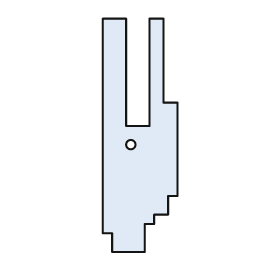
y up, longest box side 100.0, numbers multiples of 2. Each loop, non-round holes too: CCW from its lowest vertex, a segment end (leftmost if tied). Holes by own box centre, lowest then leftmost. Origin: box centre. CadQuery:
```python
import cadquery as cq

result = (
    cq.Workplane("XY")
    .moveTo(-12.0, -50.0)
    .lineTo(2.0, -50.0)
    .lineTo(2.0, -38.0)
    .lineTo(6.0, -38.0)
    .lineTo(6.0, -34.0)
    .lineTo(12.0, -34.0)
    .lineTo(12.0, -26.0)
    .lineTo(16.0, -26.0)
    .lineTo(16.0, 14.0)
    .lineTo(10.0, 14.0)
    .lineTo(10.0, 50.0)
    .lineTo(4.0, 50.0)
    .lineTo(4.0, 4.0)
    .lineTo(-6.0, 4.0)
    .lineTo(-6.0, 50.0)
    .lineTo(-16.0, 50.0)
    .lineTo(-16.0, -42.0)
    .lineTo(-12.0, -42.0)
    .close()
    .moveTo(-4.0, -4.0)
    .circle(2.0)
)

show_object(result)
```